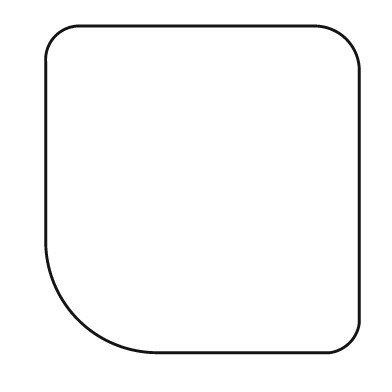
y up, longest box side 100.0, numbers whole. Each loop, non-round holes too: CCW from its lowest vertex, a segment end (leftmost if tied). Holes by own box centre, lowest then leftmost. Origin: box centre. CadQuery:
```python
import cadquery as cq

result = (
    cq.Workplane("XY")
    .moveTo(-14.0, -50.0)
    .lineTo(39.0, -50.0)
    .threePointArc((45.0, -47.0), (48.0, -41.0))
    .lineTo(48.0, 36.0)
    .threePointArc((44.0, 46.0), (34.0, 50.0))
    .lineTo(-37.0, 50.0)
    .threePointArc((-45.0, 47.0), (-48.0, 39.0))
    .lineTo(-48.0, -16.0)
    .threePointArc((-38.0, -40.0), (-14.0, -50.0))
    .close()
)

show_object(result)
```